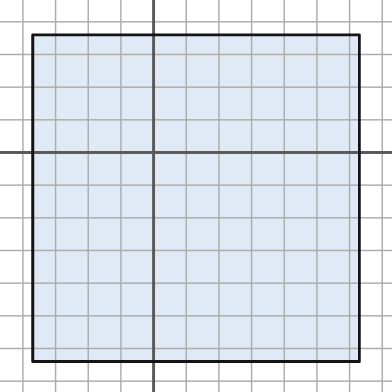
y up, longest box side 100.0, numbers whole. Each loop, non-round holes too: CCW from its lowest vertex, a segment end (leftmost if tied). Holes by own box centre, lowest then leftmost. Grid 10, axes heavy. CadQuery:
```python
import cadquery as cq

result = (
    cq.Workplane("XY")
    .moveTo(-37.0, -64.0)
    .lineTo(63.0, -64.0)
    .lineTo(63.0, 36.0)
    .lineTo(-37.0, 36.0)
    .close()
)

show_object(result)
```